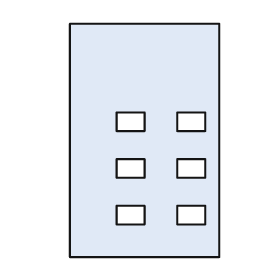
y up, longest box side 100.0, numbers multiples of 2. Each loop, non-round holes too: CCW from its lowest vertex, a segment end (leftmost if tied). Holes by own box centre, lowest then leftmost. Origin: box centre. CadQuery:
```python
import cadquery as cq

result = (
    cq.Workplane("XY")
    .moveTo(-32.0, -50.0)
    .lineTo(32.0, -50.0)
    .lineTo(32.0, 50.0)
    .lineTo(-32.0, 50.0)
    .close()
    .moveTo(-12.0, -36.0)
    .lineTo(0.0, -36.0)
    .lineTo(0.0, -28.0)
    .lineTo(-12.0, -28.0)
    .close()
    .moveTo(14.0, -36.0)
    .lineTo(26.0, -36.0)
    .lineTo(26.0, -28.0)
    .lineTo(14.0, -28.0)
    .close()
    .moveTo(-12.0, -16.0)
    .lineTo(0.0, -16.0)
    .lineTo(0.0, -8.0)
    .lineTo(-12.0, -8.0)
    .close()
    .moveTo(14.0, -16.0)
    .lineTo(26.0, -16.0)
    .lineTo(26.0, -8.0)
    .lineTo(14.0, -8.0)
    .close()
    .moveTo(-12.0, 4.0)
    .lineTo(0.0, 4.0)
    .lineTo(0.0, 12.0)
    .lineTo(-12.0, 12.0)
    .close()
    .moveTo(14.0, 4.0)
    .lineTo(26.0, 4.0)
    .lineTo(26.0, 12.0)
    .lineTo(14.0, 12.0)
    .close()
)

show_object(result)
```